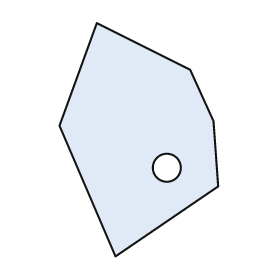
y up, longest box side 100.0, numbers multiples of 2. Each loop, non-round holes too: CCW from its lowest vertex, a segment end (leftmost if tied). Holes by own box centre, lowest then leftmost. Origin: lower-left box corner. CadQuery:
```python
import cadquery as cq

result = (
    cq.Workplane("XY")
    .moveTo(24.0, 0.0)
    .lineTo(68.0, 30.0)
    .lineTo(66.0, 58.0)
    .lineTo(56.0, 80.0)
    .lineTo(16.0, 100.0)
    .lineTo(0.0, 56.0)
    .close()
    .moveTo(46.0, 38.0)
    .circle(6.0)
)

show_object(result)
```